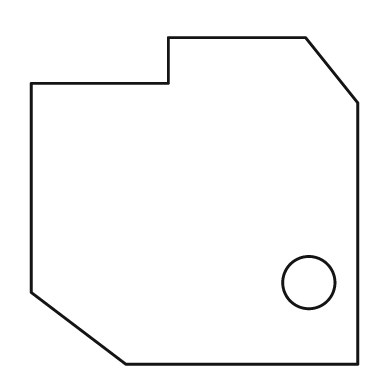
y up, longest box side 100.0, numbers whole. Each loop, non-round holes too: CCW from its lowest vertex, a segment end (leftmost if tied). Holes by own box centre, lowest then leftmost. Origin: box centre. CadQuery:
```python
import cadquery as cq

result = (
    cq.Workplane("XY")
    .moveTo(-21.0, -50.0)
    .lineTo(50.0, -50.0)
    .lineTo(50.0, 30.0)
    .lineTo(34.0, 50.0)
    .lineTo(-8.0, 50.0)
    .lineTo(-8.0, 36.0)
    .lineTo(-50.0, 36.0)
    .lineTo(-50.0, -28.0)
    .close()
    .moveTo(35.0, -25.0)
    .circle(8.0)
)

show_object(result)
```